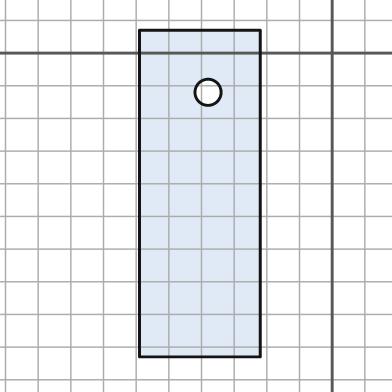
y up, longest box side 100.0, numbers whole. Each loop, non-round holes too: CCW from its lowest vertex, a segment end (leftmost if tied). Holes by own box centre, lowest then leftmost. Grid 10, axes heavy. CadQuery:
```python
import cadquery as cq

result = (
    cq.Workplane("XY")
    .moveTo(-59.0, -93.0)
    .lineTo(-22.0, -93.0)
    .lineTo(-22.0, 7.0)
    .lineTo(-59.0, 7.0)
    .close()
    .moveTo(-38.0, -12.0)
    .circle(4.0)
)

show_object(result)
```